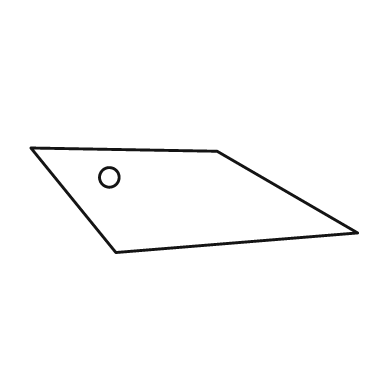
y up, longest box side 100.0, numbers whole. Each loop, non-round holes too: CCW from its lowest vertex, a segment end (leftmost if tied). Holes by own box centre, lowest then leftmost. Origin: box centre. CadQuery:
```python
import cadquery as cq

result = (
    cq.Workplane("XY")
    .moveTo(-24.0, -16.0)
    .lineTo(50.0, -10.0)
    .lineTo(7.0, 15.0)
    .lineTo(-50.0, 16.0)
    .close()
    .moveTo(-26.0, 7.0)
    .circle(3.0)
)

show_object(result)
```